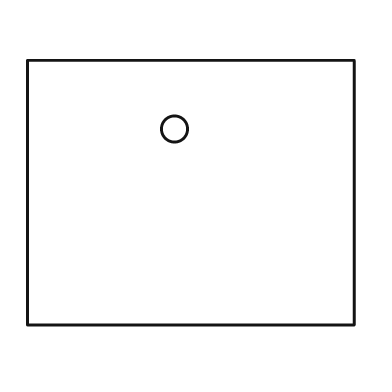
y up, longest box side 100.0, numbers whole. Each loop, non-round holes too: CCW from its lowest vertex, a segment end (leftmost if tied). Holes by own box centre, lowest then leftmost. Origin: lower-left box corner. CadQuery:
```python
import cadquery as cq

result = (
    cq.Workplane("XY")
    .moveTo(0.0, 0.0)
    .lineTo(100.0, 0.0)
    .lineTo(100.0, 81.0)
    .lineTo(0.0, 81.0)
    .close()
    .moveTo(45.0, 60.0)
    .circle(4.0)
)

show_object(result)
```